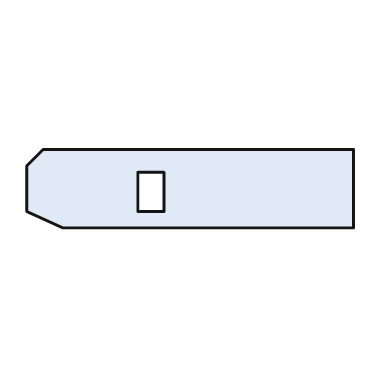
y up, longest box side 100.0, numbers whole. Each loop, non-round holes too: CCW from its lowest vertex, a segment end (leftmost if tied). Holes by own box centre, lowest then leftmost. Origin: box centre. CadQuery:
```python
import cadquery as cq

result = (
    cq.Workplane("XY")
    .moveTo(-39.0, -12.0)
    .lineTo(50.0, -12.0)
    .lineTo(50.0, 12.0)
    .lineTo(-45.0, 12.0)
    .lineTo(-50.0, 7.0)
    .lineTo(-50.0, -7.0)
    .close()
    .moveTo(-16.0, -7.0)
    .lineTo(-8.0, -7.0)
    .lineTo(-8.0, 5.0)
    .lineTo(-16.0, 5.0)
    .close()
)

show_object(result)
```